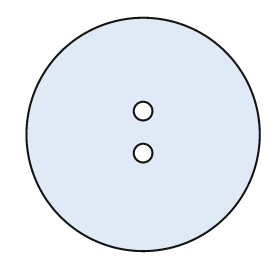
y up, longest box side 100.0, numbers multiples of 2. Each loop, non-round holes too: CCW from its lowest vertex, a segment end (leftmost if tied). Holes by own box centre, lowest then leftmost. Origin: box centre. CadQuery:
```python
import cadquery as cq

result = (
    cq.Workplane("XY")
    .moveTo(0.0, 0.0)
    .circle(50.0)
    .moveTo(0.0, -8.0)
    .circle(4.0)
    .moveTo(0.0, 10.0)
    .circle(4.0)
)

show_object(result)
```